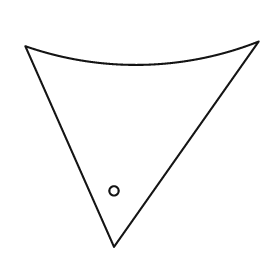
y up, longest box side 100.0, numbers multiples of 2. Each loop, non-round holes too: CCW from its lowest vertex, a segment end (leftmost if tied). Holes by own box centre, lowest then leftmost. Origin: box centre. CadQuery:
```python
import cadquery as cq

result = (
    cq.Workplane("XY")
    .moveTo(-12.0, -44.0)
    .lineTo(50.0, 44.0)
    .threePointArc((0.0, 34.0), (-50.0, 42.0))
    .close()
    .moveTo(-12.0, -20.0)
    .circle(2.0)
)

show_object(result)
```